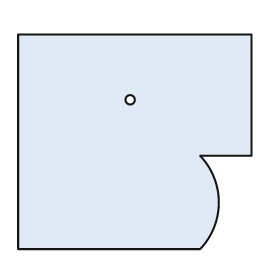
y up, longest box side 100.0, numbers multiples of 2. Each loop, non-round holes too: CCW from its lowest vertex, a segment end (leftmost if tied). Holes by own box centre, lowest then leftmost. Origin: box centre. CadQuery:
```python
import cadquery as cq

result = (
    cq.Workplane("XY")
    .moveTo(-50.0, -46.0)
    .lineTo(28.0, -46.0)
    .threePointArc((36.0, -26.0), (28.0, -6.0))
    .lineTo(50.0, -6.0)
    .lineTo(50.0, 46.0)
    .lineTo(-50.0, 46.0)
    .close()
    .moveTo(-2.0, 18.0)
    .circle(2.0)
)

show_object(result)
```